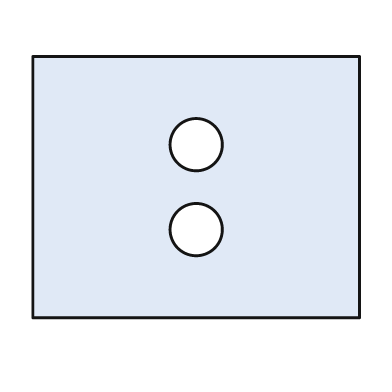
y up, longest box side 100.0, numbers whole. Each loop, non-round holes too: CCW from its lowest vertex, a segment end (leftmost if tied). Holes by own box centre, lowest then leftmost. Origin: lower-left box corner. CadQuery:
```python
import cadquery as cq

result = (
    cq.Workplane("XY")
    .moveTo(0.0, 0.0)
    .lineTo(100.0, 0.0)
    .lineTo(100.0, 80.0)
    .lineTo(0.0, 80.0)
    .close()
    .moveTo(50.0, 27.0)
    .circle(8.0)
    .moveTo(50.0, 53.0)
    .circle(8.0)
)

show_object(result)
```